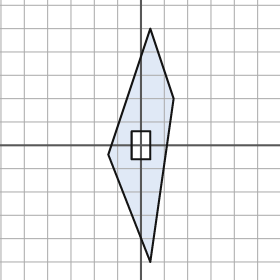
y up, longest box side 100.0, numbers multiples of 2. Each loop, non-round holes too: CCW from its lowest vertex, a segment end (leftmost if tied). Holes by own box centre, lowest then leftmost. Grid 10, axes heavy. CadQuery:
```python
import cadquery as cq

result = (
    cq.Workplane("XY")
    .moveTo(4.0, -50.0)
    .lineTo(14.0, 20.0)
    .lineTo(4.0, 50.0)
    .lineTo(-14.0, -4.0)
    .close()
    .moveTo(-4.0, -6.0)
    .lineTo(4.0, -6.0)
    .lineTo(4.0, 6.0)
    .lineTo(-4.0, 6.0)
    .close()
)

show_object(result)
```